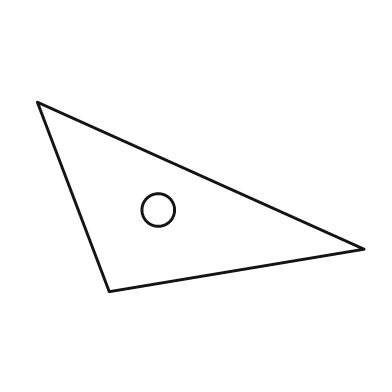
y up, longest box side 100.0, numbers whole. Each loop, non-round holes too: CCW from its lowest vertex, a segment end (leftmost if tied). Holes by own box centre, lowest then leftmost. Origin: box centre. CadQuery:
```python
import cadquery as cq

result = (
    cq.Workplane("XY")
    .moveTo(-28.0, -29.0)
    .lineTo(50.0, -16.0)
    .lineTo(-50.0, 29.0)
    .close()
    .moveTo(-13.0, -4.0)
    .circle(5.0)
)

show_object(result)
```